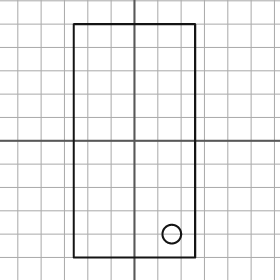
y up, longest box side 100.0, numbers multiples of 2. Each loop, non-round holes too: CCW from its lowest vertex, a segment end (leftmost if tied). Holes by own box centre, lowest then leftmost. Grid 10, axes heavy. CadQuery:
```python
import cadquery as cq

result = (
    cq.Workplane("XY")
    .moveTo(-26.0, -50.0)
    .lineTo(26.0, -50.0)
    .lineTo(26.0, 50.0)
    .lineTo(-26.0, 50.0)
    .close()
    .moveTo(16.0, -40.0)
    .circle(4.0)
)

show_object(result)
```